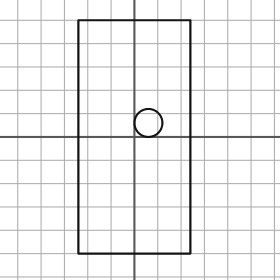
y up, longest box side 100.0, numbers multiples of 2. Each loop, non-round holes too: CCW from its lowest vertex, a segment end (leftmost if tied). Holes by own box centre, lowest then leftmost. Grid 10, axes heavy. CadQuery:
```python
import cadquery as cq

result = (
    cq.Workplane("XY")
    .moveTo(-24.0, -50.0)
    .lineTo(24.0, -50.0)
    .lineTo(24.0, 50.0)
    .lineTo(-24.0, 50.0)
    .close()
    .moveTo(6.0, 6.0)
    .circle(6.0)
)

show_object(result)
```